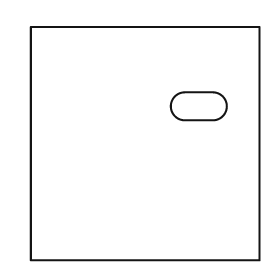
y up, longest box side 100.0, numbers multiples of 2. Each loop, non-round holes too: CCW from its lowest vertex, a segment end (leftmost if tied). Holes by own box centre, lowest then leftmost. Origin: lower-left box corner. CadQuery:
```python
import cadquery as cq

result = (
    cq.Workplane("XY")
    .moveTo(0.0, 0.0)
    .lineTo(98.0, 0.0)
    .lineTo(98.0, 100.0)
    .lineTo(0.0, 100.0)
    .close()
    .moveTo(66.0, 60.0)
    .lineTo(78.0, 60.0)
    .threePointArc((84.0, 66.0), (78.0, 72.0))
    .lineTo(66.0, 72.0)
    .threePointArc((60.0, 66.0), (66.0, 60.0))
    .close()
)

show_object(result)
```